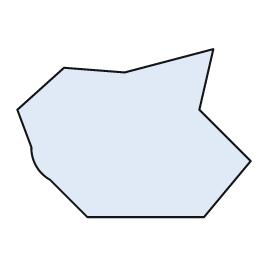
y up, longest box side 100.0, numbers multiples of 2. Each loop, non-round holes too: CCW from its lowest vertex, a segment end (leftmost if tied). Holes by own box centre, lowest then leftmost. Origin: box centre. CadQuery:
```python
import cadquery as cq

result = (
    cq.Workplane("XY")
    .moveTo(-20.0, -36.0)
    .lineTo(30.0, -36.0)
    .lineTo(50.0, -12.0)
    .lineTo(28.0, 10.0)
    .lineTo(34.0, 36.0)
    .lineTo(-4.0, 26.0)
    .lineTo(-30.0, 28.0)
    .lineTo(-50.0, 10.0)
    .lineTo(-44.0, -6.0)
    .threePointArc((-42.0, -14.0), (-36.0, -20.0))
    .close()
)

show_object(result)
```